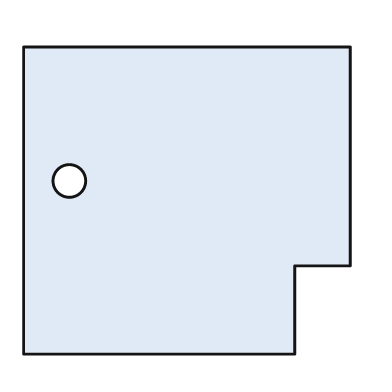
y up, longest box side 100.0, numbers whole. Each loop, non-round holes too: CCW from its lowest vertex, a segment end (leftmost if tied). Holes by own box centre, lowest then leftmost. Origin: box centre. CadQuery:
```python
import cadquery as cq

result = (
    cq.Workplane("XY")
    .moveTo(-50.0, -47.0)
    .lineTo(33.0, -47.0)
    .lineTo(33.0, -20.0)
    .lineTo(50.0, -20.0)
    .lineTo(50.0, 47.0)
    .lineTo(-50.0, 47.0)
    .close()
    .moveTo(-36.0, 6.0)
    .circle(5.0)
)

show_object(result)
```